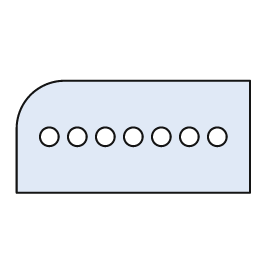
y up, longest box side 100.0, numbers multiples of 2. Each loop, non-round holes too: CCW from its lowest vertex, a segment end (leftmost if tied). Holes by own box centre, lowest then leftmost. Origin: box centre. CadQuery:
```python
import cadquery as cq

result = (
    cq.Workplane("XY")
    .moveTo(-50.0, -24.0)
    .lineTo(50.0, -24.0)
    .lineTo(50.0, 24.0)
    .lineTo(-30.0, 24.0)
    .threePointArc((-44.0, 18.0), (-50.0, 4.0))
    .close()
    .moveTo(-36.0, 0.0)
    .circle(4.0)
    .moveTo(-24.0, 0.0)
    .circle(4.0)
    .moveTo(-12.0, 0.0)
    .circle(4.0)
    .moveTo(0.0, 0.0)
    .circle(4.0)
    .moveTo(12.0, 0.0)
    .circle(4.0)
    .moveTo(24.0, 0.0)
    .circle(4.0)
    .moveTo(36.0, 0.0)
    .circle(4.0)
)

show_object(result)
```